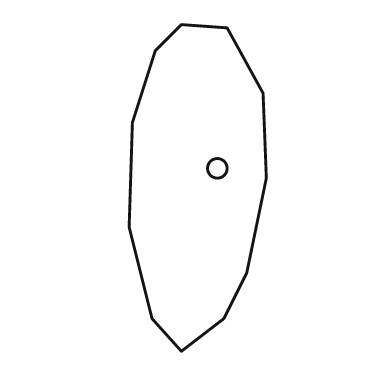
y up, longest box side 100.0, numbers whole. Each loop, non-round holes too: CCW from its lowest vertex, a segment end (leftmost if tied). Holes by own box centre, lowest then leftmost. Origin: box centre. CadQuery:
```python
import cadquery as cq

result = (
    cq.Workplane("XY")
    .moveTo(-5.0, -50.0)
    .lineTo(8.0, -40.0)
    .lineTo(15.0, -26.0)
    .lineTo(21.0, 3.0)
    .lineTo(20.0, 29.0)
    .lineTo(9.0, 49.0)
    .lineTo(-5.0, 50.0)
    .lineTo(-13.0, 42.0)
    .lineTo(-20.0, 20.0)
    .lineTo(-21.0, -12.0)
    .lineTo(-14.0, -40.0)
    .close()
    .moveTo(6.0, 6.0)
    .circle(3.0)
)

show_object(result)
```